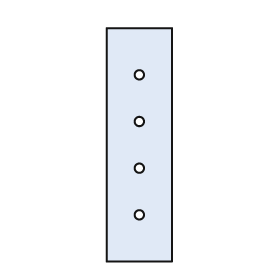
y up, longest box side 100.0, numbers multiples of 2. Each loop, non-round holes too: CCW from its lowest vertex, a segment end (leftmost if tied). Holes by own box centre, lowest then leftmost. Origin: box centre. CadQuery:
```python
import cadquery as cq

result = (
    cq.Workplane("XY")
    .moveTo(-14.0, -50.0)
    .lineTo(14.0, -50.0)
    .lineTo(14.0, 50.0)
    .lineTo(-14.0, 50.0)
    .close()
    .moveTo(0.0, -30.0)
    .circle(2.0)
    .moveTo(0.0, -10.0)
    .circle(2.0)
    .moveTo(0.0, 10.0)
    .circle(2.0)
    .moveTo(0.0, 30.0)
    .circle(2.0)
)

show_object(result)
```